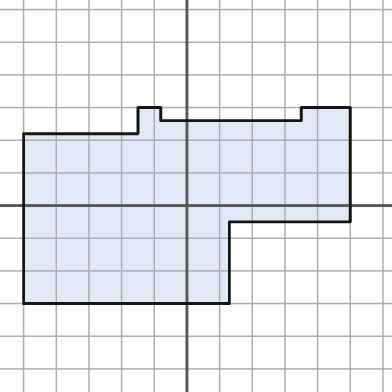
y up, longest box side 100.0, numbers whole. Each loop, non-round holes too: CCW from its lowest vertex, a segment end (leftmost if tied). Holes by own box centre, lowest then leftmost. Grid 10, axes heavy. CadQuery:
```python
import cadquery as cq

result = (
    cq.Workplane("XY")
    .moveTo(-50.0, -30.0)
    .lineTo(13.0, -30.0)
    .lineTo(13.0, -5.0)
    .lineTo(50.0, -5.0)
    .lineTo(50.0, 30.0)
    .lineTo(35.0, 30.0)
    .lineTo(35.0, 26.0)
    .lineTo(-8.0, 26.0)
    .lineTo(-8.0, 30.0)
    .lineTo(-15.0, 30.0)
    .lineTo(-15.0, 22.0)
    .lineTo(-50.0, 22.0)
    .close()
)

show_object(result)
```